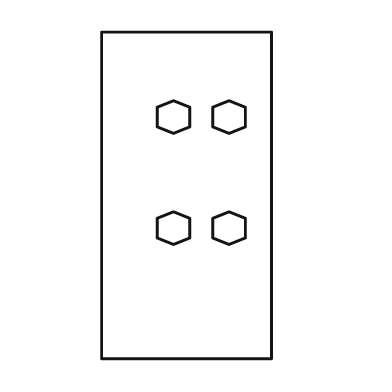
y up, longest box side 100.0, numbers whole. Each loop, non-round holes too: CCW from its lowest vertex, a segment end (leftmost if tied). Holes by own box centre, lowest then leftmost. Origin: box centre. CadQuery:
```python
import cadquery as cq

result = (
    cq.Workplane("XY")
    .moveTo(-26.0, -50.0)
    .lineTo(26.0, -50.0)
    .lineTo(26.0, 50.0)
    .lineTo(-26.0, 50.0)
    .close()
    .moveTo(-4.0, -15.0)
    .lineTo(1.0, -13.0)
    .lineTo(1.0, -7.0)
    .lineTo(-4.0, -5.0)
    .lineTo(-9.0, -7.0)
    .lineTo(-9.0, -13.0)
    .close()
    .moveTo(13.0, -15.0)
    .lineTo(18.0, -13.0)
    .lineTo(18.0, -7.0)
    .lineTo(13.0, -5.0)
    .lineTo(8.0, -7.0)
    .lineTo(8.0, -13.0)
    .close()
    .moveTo(-4.0, 19.0)
    .lineTo(1.0, 21.0)
    .lineTo(1.0, 27.0)
    .lineTo(-4.0, 29.0)
    .lineTo(-9.0, 27.0)
    .lineTo(-9.0, 21.0)
    .close()
    .moveTo(13.0, 19.0)
    .lineTo(18.0, 21.0)
    .lineTo(18.0, 27.0)
    .lineTo(13.0, 29.0)
    .lineTo(8.0, 27.0)
    .lineTo(8.0, 21.0)
    .close()
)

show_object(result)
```